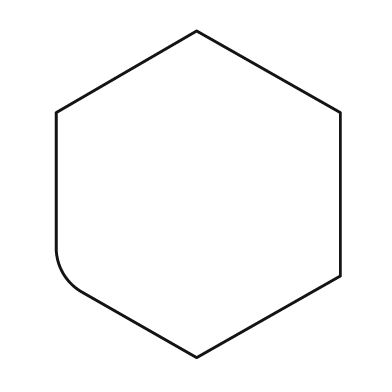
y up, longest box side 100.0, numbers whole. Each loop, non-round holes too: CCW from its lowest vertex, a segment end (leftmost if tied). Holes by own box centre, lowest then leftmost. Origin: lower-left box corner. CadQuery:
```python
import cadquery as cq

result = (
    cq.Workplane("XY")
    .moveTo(43.0, 0.0)
    .lineTo(87.0, 25.0)
    .lineTo(87.0, 75.0)
    .lineTo(43.0, 100.0)
    .lineTo(0.0, 75.0)
    .lineTo(0.0, 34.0)
    .threePointArc((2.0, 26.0), (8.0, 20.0))
    .close()
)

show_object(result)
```